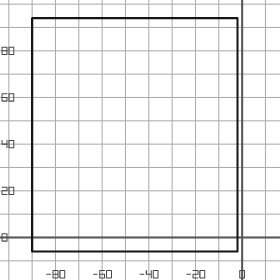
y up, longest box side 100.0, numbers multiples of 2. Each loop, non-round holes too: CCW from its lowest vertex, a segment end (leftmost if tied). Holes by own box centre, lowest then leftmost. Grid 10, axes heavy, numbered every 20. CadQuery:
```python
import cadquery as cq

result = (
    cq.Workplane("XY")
    .moveTo(-90.0, -6.0)
    .lineTo(-2.0, -6.0)
    .lineTo(-2.0, 94.0)
    .lineTo(-90.0, 94.0)
    .close()
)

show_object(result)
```